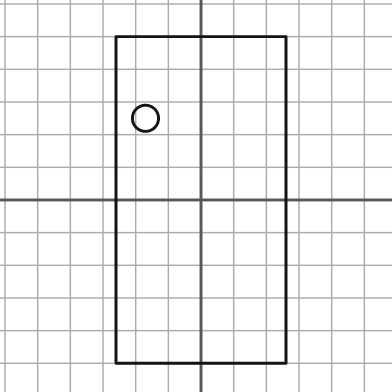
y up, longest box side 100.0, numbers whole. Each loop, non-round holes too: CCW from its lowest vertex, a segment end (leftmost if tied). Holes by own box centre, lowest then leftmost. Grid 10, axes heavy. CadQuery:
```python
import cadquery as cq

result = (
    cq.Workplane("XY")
    .moveTo(-26.0, -50.0)
    .lineTo(26.0, -50.0)
    .lineTo(26.0, 50.0)
    .lineTo(-26.0, 50.0)
    .close()
    .moveTo(-17.0, 25.0)
    .circle(4.0)
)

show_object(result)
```